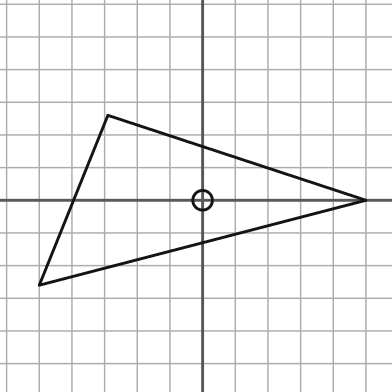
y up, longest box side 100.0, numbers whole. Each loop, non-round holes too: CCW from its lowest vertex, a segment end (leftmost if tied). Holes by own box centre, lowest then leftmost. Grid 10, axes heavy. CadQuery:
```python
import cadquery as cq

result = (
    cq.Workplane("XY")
    .moveTo(-50.0, -26.0)
    .lineTo(50.0, 0.0)
    .lineTo(-29.0, 26.0)
    .close()
    .moveTo(0.0, 0.0)
    .circle(3.0)
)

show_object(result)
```